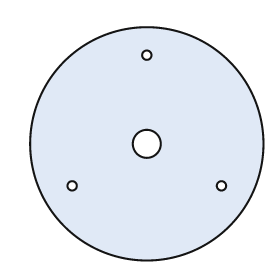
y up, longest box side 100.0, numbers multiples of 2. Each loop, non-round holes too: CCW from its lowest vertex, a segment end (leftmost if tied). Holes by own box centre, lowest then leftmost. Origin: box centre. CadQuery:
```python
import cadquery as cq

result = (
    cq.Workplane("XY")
    .moveTo(0.0, 0.0)
    .circle(50.0)
    .moveTo(-32.0, -18.0)
    .circle(2.0)
    .moveTo(32.0, -18.0)
    .circle(2.0)
    .moveTo(0.0, 0.0)
    .circle(6.0)
    .moveTo(0.0, 38.0)
    .circle(2.0)
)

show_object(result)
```